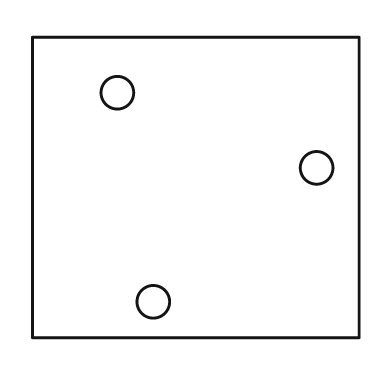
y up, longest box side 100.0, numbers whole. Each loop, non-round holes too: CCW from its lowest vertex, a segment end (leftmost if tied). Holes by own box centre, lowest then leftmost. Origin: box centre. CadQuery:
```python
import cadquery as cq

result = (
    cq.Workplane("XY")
    .moveTo(-50.0, -46.0)
    .lineTo(50.0, -46.0)
    .lineTo(50.0, 46.0)
    .lineTo(-50.0, 46.0)
    .close()
    .moveTo(-13.0, -35.0)
    .circle(5.0)
    .moveTo(37.0, 6.0)
    .circle(5.0)
    .moveTo(-24.0, 29.0)
    .circle(5.0)
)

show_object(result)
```